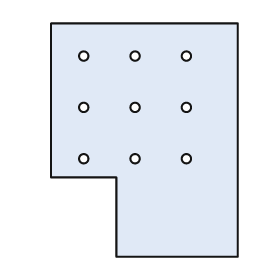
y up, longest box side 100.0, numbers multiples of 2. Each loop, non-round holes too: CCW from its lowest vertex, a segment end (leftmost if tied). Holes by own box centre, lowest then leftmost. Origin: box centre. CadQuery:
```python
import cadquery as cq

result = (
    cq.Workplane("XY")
    .moveTo(-12.0, -50.0)
    .lineTo(40.0, -50.0)
    .lineTo(40.0, 50.0)
    .lineTo(-40.0, 50.0)
    .lineTo(-40.0, -16.0)
    .lineTo(-12.0, -16.0)
    .close()
    .moveTo(-26.0, -8.0)
    .circle(2.0)
    .moveTo(-4.0, -8.0)
    .circle(2.0)
    .moveTo(18.0, -8.0)
    .circle(2.0)
    .moveTo(-26.0, 14.0)
    .circle(2.0)
    .moveTo(-4.0, 14.0)
    .circle(2.0)
    .moveTo(18.0, 14.0)
    .circle(2.0)
    .moveTo(-26.0, 36.0)
    .circle(2.0)
    .moveTo(-4.0, 36.0)
    .circle(2.0)
    .moveTo(18.0, 36.0)
    .circle(2.0)
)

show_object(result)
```